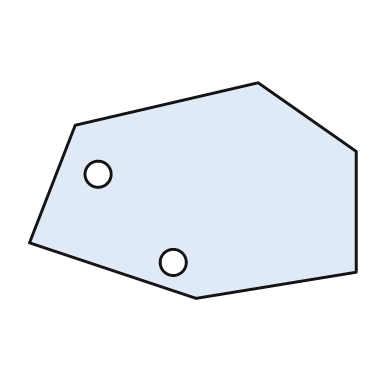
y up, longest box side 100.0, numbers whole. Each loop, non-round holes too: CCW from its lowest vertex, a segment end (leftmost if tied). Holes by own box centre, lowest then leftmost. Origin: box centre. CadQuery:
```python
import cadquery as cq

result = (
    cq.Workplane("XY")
    .moveTo(1.0, -33.0)
    .lineTo(50.0, -25.0)
    .lineTo(50.0, 12.0)
    .lineTo(20.0, 33.0)
    .lineTo(-36.0, 20.0)
    .lineTo(-50.0, -16.0)
    .close()
    .moveTo(-6.0, -22.0)
    .circle(4.0)
    .moveTo(-29.0, 5.0)
    .circle(4.0)
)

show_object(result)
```